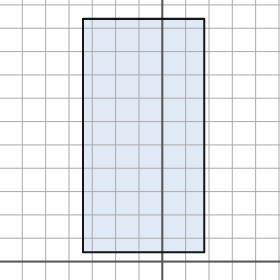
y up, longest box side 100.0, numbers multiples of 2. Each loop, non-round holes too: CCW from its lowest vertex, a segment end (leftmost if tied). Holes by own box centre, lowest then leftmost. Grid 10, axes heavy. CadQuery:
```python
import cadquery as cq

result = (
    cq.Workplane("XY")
    .moveTo(-34.0, 4.0)
    .lineTo(18.0, 4.0)
    .lineTo(18.0, 104.0)
    .lineTo(-34.0, 104.0)
    .close()
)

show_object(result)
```